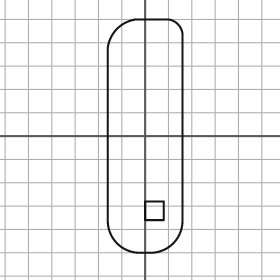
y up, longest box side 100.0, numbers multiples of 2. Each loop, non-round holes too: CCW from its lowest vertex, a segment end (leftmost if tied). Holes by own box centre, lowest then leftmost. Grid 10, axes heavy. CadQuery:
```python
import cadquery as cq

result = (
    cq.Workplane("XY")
    .moveTo(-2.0, -50.0)
    .lineTo(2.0, -50.0)
    .threePointArc((12.0, -46.0), (16.0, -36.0))
    .lineTo(16.0, 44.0)
    .threePointArc((14.0, 48.0), (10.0, 50.0))
    .lineTo(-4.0, 50.0)
    .threePointArc((-12.0, 46.0), (-16.0, 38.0))
    .lineTo(-16.0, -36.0)
    .threePointArc((-12.0, -46.0), (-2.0, -50.0))
    .close()
    .moveTo(0.0, -36.0)
    .lineTo(8.0, -36.0)
    .lineTo(8.0, -28.0)
    .lineTo(0.0, -28.0)
    .close()
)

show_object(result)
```